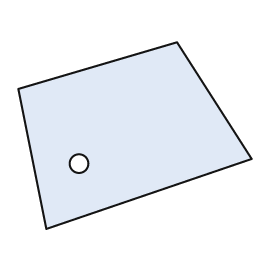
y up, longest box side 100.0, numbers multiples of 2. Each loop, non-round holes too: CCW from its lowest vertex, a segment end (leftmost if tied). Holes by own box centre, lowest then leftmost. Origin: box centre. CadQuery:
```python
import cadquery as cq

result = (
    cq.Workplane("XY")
    .moveTo(-38.0, -40.0)
    .lineTo(50.0, -10.0)
    .lineTo(18.0, 40.0)
    .lineTo(-50.0, 20.0)
    .close()
    .moveTo(-24.0, -12.0)
    .circle(4.0)
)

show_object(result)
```